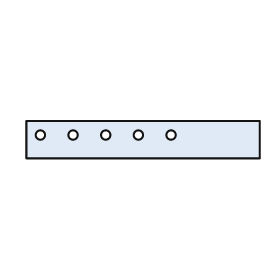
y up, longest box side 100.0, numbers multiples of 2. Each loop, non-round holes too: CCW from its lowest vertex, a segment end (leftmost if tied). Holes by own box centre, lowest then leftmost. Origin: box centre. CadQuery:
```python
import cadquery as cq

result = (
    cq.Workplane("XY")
    .moveTo(-50.0, -8.0)
    .lineTo(50.0, -8.0)
    .lineTo(50.0, 8.0)
    .lineTo(-50.0, 8.0)
    .close()
    .moveTo(-44.0, 2.0)
    .circle(2.0)
    .moveTo(-30.0, 2.0)
    .circle(2.0)
    .moveTo(-16.0, 2.0)
    .circle(2.0)
    .moveTo(-2.0, 2.0)
    .circle(2.0)
    .moveTo(12.0, 2.0)
    .circle(2.0)
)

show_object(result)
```